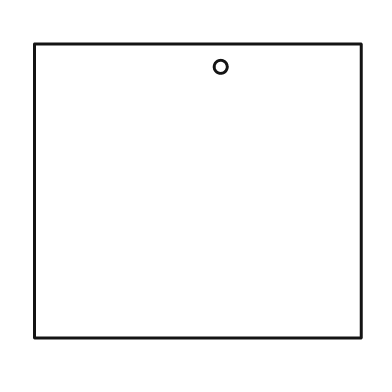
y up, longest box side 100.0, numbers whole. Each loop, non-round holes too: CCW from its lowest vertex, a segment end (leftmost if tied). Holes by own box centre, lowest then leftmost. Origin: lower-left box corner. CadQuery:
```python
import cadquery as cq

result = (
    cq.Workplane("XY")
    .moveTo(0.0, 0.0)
    .lineTo(100.0, 0.0)
    .lineTo(100.0, 90.0)
    .lineTo(0.0, 90.0)
    .close()
    .moveTo(57.0, 83.0)
    .circle(2.0)
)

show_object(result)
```